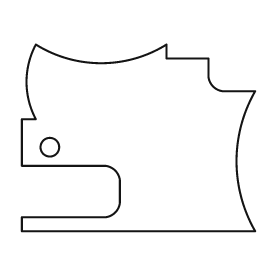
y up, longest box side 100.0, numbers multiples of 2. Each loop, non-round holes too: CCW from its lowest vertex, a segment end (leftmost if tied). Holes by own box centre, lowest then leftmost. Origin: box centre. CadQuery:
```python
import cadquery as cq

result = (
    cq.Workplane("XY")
    .moveTo(-50.0, -40.0)
    .lineTo(50.0, -40.0)
    .threePointArc((42.0, -10.0), (50.0, 20.0))
    .lineTo(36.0, 20.0)
    .threePointArc((32.0, 22.0), (30.0, 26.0))
    .lineTo(30.0, 34.0)
    .lineTo(12.0, 34.0)
    .lineTo(12.0, 40.0)
    .threePointArc((-16.0, 32.0), (-44.0, 40.0))
    .threePointArc((-48.0, 24.0), (-44.0, 8.0))
    .lineTo(-50.0, 8.0)
    .lineTo(-50.0, -12.0)
    .lineTo(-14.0, -12.0)
    .threePointArc((-10.0, -14.0), (-8.0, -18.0))
    .lineTo(-8.0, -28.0)
    .threePointArc((-10.0, -32.0), (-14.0, -34.0))
    .lineTo(-50.0, -34.0)
    .close()
    .moveTo(-38.0, -4.0)
    .circle(4.0)
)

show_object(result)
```